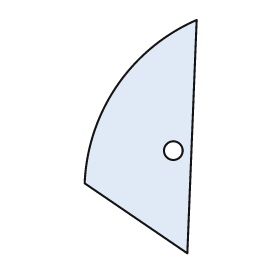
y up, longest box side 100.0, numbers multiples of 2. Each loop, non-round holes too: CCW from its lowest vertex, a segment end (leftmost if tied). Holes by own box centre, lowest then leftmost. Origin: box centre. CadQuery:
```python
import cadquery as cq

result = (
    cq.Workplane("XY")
    .moveTo(20.0, -50.0)
    .lineTo(24.0, 50.0)
    .threePointArc((-10.0, 22.0), (-24.0, -20.0))
    .close()
    .moveTo(14.0, -6.0)
    .circle(4.0)
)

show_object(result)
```